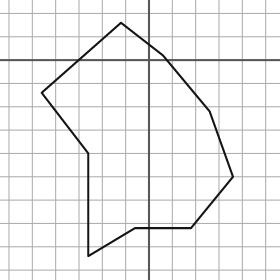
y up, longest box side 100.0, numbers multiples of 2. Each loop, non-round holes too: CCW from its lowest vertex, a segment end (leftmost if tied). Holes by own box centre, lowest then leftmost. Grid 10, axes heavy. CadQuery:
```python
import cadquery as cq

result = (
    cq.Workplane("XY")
    .moveTo(-26.0, -84.0)
    .lineTo(-6.0, -72.0)
    .lineTo(18.0, -72.0)
    .lineTo(36.0, -50.0)
    .lineTo(26.0, -22.0)
    .lineTo(6.0, 2.0)
    .lineTo(-12.0, 16.0)
    .lineTo(-46.0, -14.0)
    .lineTo(-26.0, -40.0)
    .close()
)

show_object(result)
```